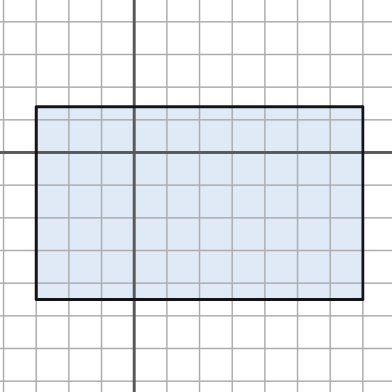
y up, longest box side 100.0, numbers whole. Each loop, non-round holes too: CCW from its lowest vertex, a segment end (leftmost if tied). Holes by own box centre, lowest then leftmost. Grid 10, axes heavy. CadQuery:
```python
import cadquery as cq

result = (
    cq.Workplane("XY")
    .moveTo(-30.0, -45.0)
    .lineTo(70.0, -45.0)
    .lineTo(70.0, 14.0)
    .lineTo(-30.0, 14.0)
    .close()
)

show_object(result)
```